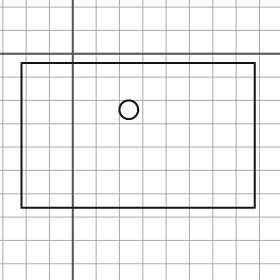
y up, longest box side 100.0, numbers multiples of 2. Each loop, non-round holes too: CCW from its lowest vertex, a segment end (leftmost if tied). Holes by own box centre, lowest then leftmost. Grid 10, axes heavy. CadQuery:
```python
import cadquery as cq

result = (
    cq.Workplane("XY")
    .moveTo(-22.0, -66.0)
    .lineTo(78.0, -66.0)
    .lineTo(78.0, -4.0)
    .lineTo(-22.0, -4.0)
    .close()
    .moveTo(24.0, -24.0)
    .circle(4.0)
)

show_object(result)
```